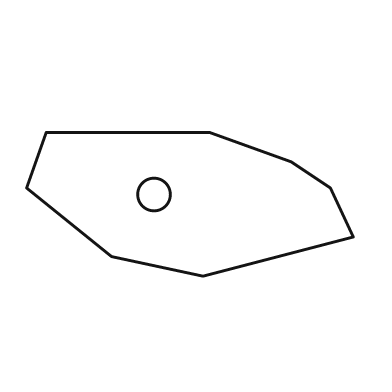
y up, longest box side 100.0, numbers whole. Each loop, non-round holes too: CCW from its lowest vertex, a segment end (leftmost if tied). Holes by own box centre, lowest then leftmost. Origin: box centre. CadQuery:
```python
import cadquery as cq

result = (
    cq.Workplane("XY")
    .moveTo(4.0, -22.0)
    .lineTo(50.0, -10.0)
    .lineTo(43.0, 5.0)
    .lineTo(31.0, 13.0)
    .lineTo(6.0, 22.0)
    .lineTo(-44.0, 22.0)
    .lineTo(-50.0, 5.0)
    .lineTo(-24.0, -16.0)
    .close()
    .moveTo(-11.0, 3.0)
    .circle(5.0)
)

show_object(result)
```